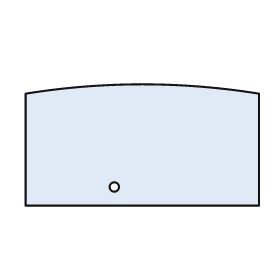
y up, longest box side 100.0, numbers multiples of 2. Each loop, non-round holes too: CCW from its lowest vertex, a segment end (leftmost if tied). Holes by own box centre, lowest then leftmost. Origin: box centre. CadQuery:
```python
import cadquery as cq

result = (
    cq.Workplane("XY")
    .moveTo(-50.0, -26.0)
    .lineTo(50.0, -26.0)
    .lineTo(50.0, 22.0)
    .threePointArc((0.0, 26.0), (-50.0, 22.0))
    .close()
    .moveTo(-12.0, -18.0)
    .circle(2.0)
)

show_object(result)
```